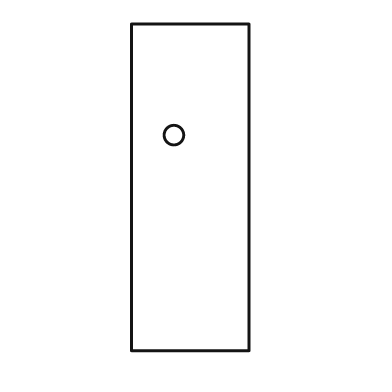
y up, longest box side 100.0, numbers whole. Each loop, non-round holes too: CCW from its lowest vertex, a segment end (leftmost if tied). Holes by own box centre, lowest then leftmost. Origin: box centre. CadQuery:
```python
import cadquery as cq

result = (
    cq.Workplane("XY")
    .moveTo(-18.0, -50.0)
    .lineTo(18.0, -50.0)
    .lineTo(18.0, 50.0)
    .lineTo(-18.0, 50.0)
    .close()
    .moveTo(-5.0, 16.0)
    .circle(3.0)
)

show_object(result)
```